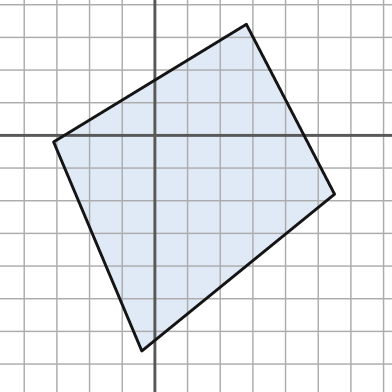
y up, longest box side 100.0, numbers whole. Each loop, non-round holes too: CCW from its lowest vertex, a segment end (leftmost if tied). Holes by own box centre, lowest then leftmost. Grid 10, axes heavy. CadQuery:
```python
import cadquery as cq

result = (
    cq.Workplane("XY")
    .moveTo(-4.0, -66.0)
    .lineTo(55.0, -18.0)
    .lineTo(28.0, 34.0)
    .lineTo(-31.0, -2.0)
    .close()
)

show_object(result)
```